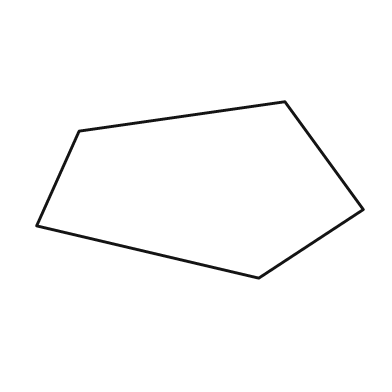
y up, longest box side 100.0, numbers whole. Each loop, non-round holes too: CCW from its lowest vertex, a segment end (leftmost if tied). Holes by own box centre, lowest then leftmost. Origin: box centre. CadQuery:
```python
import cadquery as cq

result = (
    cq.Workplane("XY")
    .moveTo(18.0, -27.0)
    .lineTo(50.0, -6.0)
    .lineTo(26.0, 27.0)
    .lineTo(-37.0, 18.0)
    .lineTo(-50.0, -11.0)
    .close()
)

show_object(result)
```